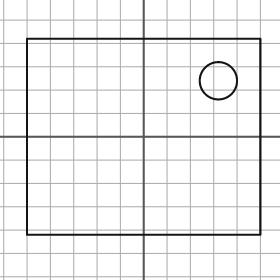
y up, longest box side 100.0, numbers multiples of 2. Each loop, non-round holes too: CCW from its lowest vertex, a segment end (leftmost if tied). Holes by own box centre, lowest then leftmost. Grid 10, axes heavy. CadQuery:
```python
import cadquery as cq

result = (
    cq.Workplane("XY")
    .moveTo(-50.0, -42.0)
    .lineTo(50.0, -42.0)
    .lineTo(50.0, 42.0)
    .lineTo(-50.0, 42.0)
    .close()
    .moveTo(32.0, 24.0)
    .circle(8.0)
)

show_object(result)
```